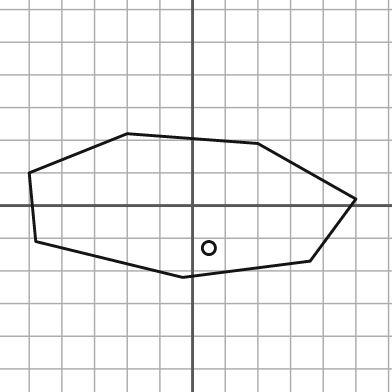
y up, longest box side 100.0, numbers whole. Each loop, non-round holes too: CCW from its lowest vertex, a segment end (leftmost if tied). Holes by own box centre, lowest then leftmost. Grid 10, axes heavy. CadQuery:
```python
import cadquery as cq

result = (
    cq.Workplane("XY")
    .moveTo(-3.0, -22.0)
    .lineTo(36.0, -17.0)
    .lineTo(50.0, 2.0)
    .lineTo(20.0, 19.0)
    .lineTo(-20.0, 22.0)
    .lineTo(-50.0, 10.0)
    .lineTo(-48.0, -11.0)
    .close()
    .moveTo(5.0, -13.0)
    .circle(2.0)
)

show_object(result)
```